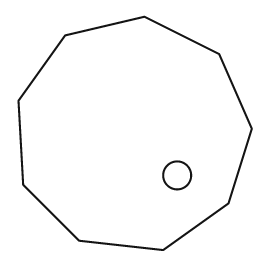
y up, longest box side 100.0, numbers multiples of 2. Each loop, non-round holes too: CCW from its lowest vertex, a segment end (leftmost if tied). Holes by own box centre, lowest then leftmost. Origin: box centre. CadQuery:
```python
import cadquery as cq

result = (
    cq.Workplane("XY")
    .moveTo(12.0, -50.0)
    .lineTo(40.0, -30.0)
    .lineTo(50.0, 2.0)
    .lineTo(36.0, 34.0)
    .lineTo(4.0, 50.0)
    .lineTo(-30.0, 42.0)
    .lineTo(-50.0, 14.0)
    .lineTo(-48.0, -22.0)
    .lineTo(-24.0, -46.0)
    .close()
    .moveTo(18.0, -18.0)
    .circle(6.0)
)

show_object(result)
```